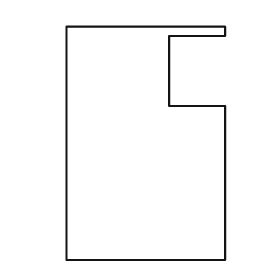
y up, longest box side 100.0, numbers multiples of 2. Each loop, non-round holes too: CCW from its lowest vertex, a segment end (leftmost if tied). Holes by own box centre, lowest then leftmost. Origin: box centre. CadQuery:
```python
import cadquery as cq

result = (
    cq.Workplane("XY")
    .moveTo(-34.0, -50.0)
    .lineTo(34.0, -50.0)
    .lineTo(34.0, 16.0)
    .lineTo(10.0, 16.0)
    .lineTo(10.0, 46.0)
    .lineTo(34.0, 46.0)
    .lineTo(34.0, 50.0)
    .lineTo(-34.0, 50.0)
    .close()
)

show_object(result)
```